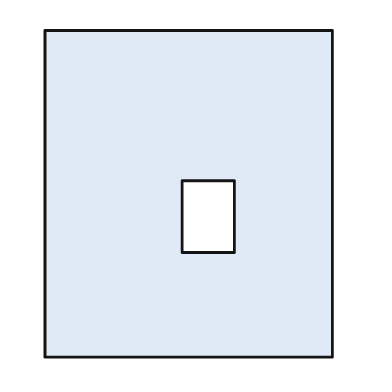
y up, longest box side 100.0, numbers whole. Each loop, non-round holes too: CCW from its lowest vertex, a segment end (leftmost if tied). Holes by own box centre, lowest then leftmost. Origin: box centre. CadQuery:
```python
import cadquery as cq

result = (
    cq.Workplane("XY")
    .moveTo(-44.0, -50.0)
    .lineTo(44.0, -50.0)
    .lineTo(44.0, 50.0)
    .lineTo(-44.0, 50.0)
    .close()
    .moveTo(-2.0, -18.0)
    .lineTo(14.0, -18.0)
    .lineTo(14.0, 4.0)
    .lineTo(-2.0, 4.0)
    .close()
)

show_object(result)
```